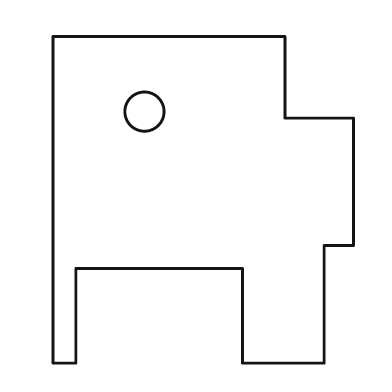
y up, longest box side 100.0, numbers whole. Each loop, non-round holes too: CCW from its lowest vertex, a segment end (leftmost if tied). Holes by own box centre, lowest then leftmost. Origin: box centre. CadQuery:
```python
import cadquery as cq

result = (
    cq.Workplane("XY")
    .moveTo(-46.0, -50.0)
    .lineTo(-39.0, -50.0)
    .lineTo(-39.0, -21.0)
    .lineTo(12.0, -21.0)
    .lineTo(12.0, -50.0)
    .lineTo(37.0, -50.0)
    .lineTo(37.0, -14.0)
    .lineTo(46.0, -14.0)
    .lineTo(46.0, 25.0)
    .lineTo(25.0, 25.0)
    .lineTo(25.0, 50.0)
    .lineTo(-46.0, 50.0)
    .close()
    .moveTo(-18.0, 27.0)
    .circle(6.0)
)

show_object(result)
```